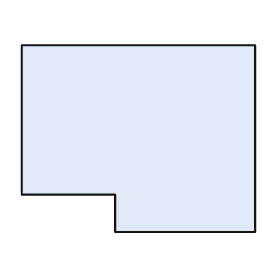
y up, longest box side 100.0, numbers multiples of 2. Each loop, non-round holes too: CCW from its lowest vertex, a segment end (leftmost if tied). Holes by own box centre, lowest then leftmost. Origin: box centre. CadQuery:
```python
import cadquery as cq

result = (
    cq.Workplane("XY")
    .moveTo(-10.0, -40.0)
    .lineTo(50.0, -40.0)
    .lineTo(50.0, 40.0)
    .lineTo(-50.0, 40.0)
    .lineTo(-50.0, -24.0)
    .lineTo(-10.0, -24.0)
    .close()
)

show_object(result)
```